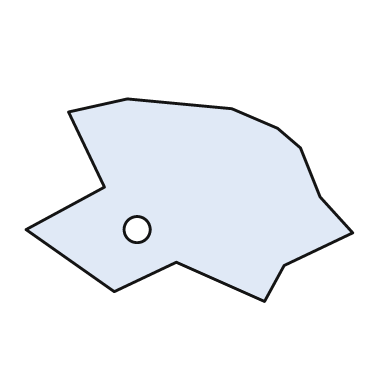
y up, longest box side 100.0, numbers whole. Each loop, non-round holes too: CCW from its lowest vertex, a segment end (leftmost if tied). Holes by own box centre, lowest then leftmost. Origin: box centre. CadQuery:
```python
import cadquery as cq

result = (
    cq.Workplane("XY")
    .moveTo(23.0, -31.0)
    .lineTo(29.0, -20.0)
    .lineTo(50.0, -10.0)
    .lineTo(40.0, 1.0)
    .lineTo(34.0, 16.0)
    .lineTo(27.0, 22.0)
    .lineTo(13.0, 28.0)
    .lineTo(-19.0, 31.0)
    .lineTo(-37.0, 27.0)
    .lineTo(-26.0, 4.0)
    .lineTo(-50.0, -9.0)
    .lineTo(-23.0, -28.0)
    .lineTo(-4.0, -19.0)
    .close()
    .moveTo(-16.0, -9.0)
    .circle(4.0)
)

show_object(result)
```